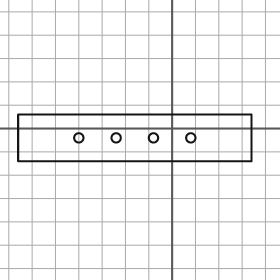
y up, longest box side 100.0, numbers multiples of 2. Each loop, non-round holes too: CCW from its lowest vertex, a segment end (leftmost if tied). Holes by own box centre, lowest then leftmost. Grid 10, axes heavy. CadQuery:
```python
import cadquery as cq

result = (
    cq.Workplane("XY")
    .moveTo(-66.0, -14.0)
    .lineTo(34.0, -14.0)
    .lineTo(34.0, 6.0)
    .lineTo(-66.0, 6.0)
    .close()
    .moveTo(-40.0, -4.0)
    .circle(2.0)
    .moveTo(-24.0, -4.0)
    .circle(2.0)
    .moveTo(-8.0, -4.0)
    .circle(2.0)
    .moveTo(8.0, -4.0)
    .circle(2.0)
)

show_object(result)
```